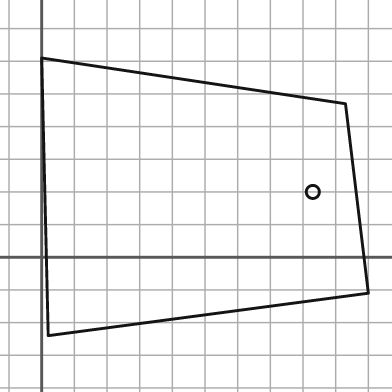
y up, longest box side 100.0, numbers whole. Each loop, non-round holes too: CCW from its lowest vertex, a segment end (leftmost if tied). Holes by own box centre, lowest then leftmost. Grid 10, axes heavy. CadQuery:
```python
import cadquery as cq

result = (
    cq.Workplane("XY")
    .moveTo(2.0, -24.0)
    .lineTo(100.0, -11.0)
    .lineTo(93.0, 47.0)
    .lineTo(0.0, 61.0)
    .close()
    .moveTo(83.0, 20.0)
    .circle(2.0)
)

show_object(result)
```